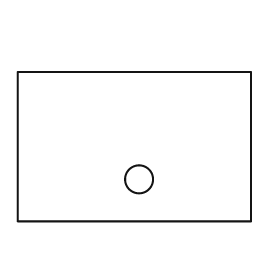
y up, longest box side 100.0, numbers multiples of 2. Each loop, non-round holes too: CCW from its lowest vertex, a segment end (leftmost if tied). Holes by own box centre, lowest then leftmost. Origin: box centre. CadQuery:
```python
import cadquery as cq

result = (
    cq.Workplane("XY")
    .moveTo(-50.0, -32.0)
    .lineTo(50.0, -32.0)
    .lineTo(50.0, 32.0)
    .lineTo(-50.0, 32.0)
    .close()
    .moveTo(2.0, -14.0)
    .circle(6.0)
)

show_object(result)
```